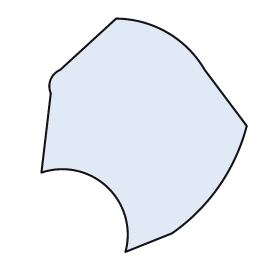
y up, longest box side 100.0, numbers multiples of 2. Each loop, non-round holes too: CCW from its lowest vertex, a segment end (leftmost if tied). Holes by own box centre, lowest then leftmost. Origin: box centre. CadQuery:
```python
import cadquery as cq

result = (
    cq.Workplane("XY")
    .moveTo(-8.0, -50.0)
    .lineTo(12.0, -42.0)
    .threePointArc((32.0, -22.0), (44.0, 4.0))
    .lineTo(26.0, 28.0)
    .threePointArc((10.0, 44.0), (-12.0, 50.0))
    .lineTo(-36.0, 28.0)
    .threePointArc((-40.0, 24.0), (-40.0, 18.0))
    .lineTo(-44.0, -16.0)
    .threePointArc((-16.0, -22.0), (-8.0, -50.0))
    .close()
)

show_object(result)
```